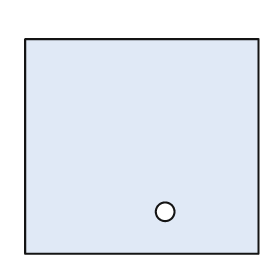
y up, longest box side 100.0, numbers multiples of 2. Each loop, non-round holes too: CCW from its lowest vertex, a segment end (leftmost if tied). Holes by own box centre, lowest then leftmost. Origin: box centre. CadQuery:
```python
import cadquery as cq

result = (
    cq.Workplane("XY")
    .moveTo(-50.0, -46.0)
    .lineTo(50.0, -46.0)
    .lineTo(50.0, 46.0)
    .lineTo(-50.0, 46.0)
    .close()
    .moveTo(10.0, -28.0)
    .circle(4.0)
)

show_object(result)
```